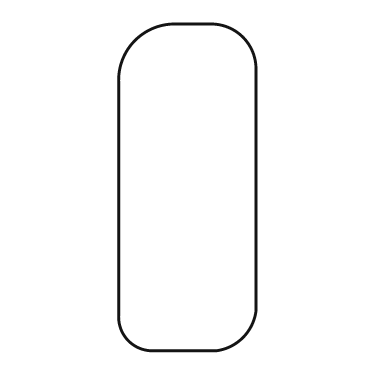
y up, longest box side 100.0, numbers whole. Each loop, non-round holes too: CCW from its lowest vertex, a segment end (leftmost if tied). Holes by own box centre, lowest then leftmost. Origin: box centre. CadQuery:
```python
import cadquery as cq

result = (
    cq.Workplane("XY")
    .moveTo(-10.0, -50.0)
    .lineTo(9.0, -50.0)
    .threePointArc((17.0, -46.0), (21.0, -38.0))
    .lineTo(21.0, 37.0)
    .threePointArc((17.0, 46.0), (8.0, 50.0))
    .lineTo(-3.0, 50.0)
    .threePointArc((-16.0, 45.0), (-21.0, 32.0))
    .lineTo(-21.0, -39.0)
    .threePointArc((-18.0, -47.0), (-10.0, -50.0))
    .close()
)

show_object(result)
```